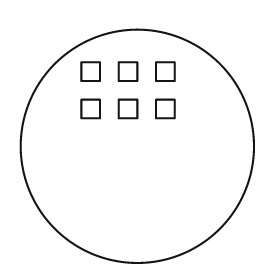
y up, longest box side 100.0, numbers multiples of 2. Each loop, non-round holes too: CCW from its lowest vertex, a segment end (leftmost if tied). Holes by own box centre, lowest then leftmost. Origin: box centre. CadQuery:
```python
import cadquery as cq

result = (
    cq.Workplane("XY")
    .moveTo(0.0, 0.0)
    .circle(50.0)
    .moveTo(-24.0, 12.0)
    .lineTo(-16.0, 12.0)
    .lineTo(-16.0, 20.0)
    .lineTo(-24.0, 20.0)
    .close()
    .moveTo(-8.0, 12.0)
    .lineTo(0.0, 12.0)
    .lineTo(0.0, 20.0)
    .lineTo(-8.0, 20.0)
    .close()
    .moveTo(8.0, 12.0)
    .lineTo(16.0, 12.0)
    .lineTo(16.0, 20.0)
    .lineTo(8.0, 20.0)
    .close()
    .moveTo(-24.0, 28.0)
    .lineTo(-16.0, 28.0)
    .lineTo(-16.0, 36.0)
    .lineTo(-24.0, 36.0)
    .close()
    .moveTo(-8.0, 28.0)
    .lineTo(0.0, 28.0)
    .lineTo(0.0, 36.0)
    .lineTo(-8.0, 36.0)
    .close()
    .moveTo(8.0, 28.0)
    .lineTo(16.0, 28.0)
    .lineTo(16.0, 36.0)
    .lineTo(8.0, 36.0)
    .close()
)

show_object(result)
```